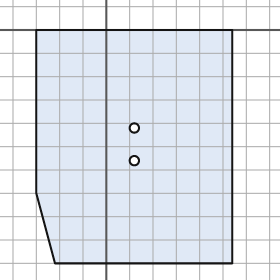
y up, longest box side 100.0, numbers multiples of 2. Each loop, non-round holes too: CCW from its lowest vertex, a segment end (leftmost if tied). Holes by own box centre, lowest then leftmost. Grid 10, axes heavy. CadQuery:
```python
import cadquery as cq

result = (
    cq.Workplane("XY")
    .moveTo(-22.0, -100.0)
    .lineTo(54.0, -100.0)
    .lineTo(54.0, 0.0)
    .lineTo(-30.0, 0.0)
    .lineTo(-30.0, -70.0)
    .close()
    .moveTo(12.0, -56.0)
    .circle(2.0)
    .moveTo(12.0, -42.0)
    .circle(2.0)
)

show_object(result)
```